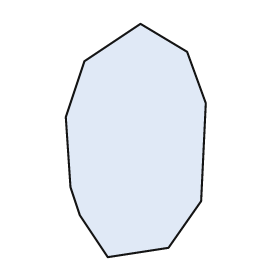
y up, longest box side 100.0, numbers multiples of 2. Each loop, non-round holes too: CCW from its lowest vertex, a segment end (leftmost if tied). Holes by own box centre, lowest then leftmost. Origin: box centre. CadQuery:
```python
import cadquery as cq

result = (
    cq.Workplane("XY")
    .moveTo(-12.0, -50.0)
    .lineTo(14.0, -46.0)
    .lineTo(28.0, -26.0)
    .lineTo(30.0, 16.0)
    .lineTo(22.0, 38.0)
    .lineTo(2.0, 50.0)
    .lineTo(-22.0, 34.0)
    .lineTo(-30.0, 10.0)
    .lineTo(-28.0, -20.0)
    .lineTo(-24.0, -32.0)
    .close()
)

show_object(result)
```